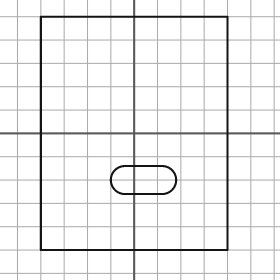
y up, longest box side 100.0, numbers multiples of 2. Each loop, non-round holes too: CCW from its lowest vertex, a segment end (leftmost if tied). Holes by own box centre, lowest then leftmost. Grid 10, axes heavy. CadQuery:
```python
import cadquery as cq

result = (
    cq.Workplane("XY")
    .moveTo(-40.0, -50.0)
    .lineTo(40.0, -50.0)
    .lineTo(40.0, 50.0)
    .lineTo(-40.0, 50.0)
    .close()
    .moveTo(-4.0, -26.0)
    .lineTo(12.0, -26.0)
    .threePointArc((18.0, -20.0), (12.0, -14.0))
    .lineTo(-4.0, -14.0)
    .threePointArc((-10.0, -20.0), (-4.0, -26.0))
    .close()
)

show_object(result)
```